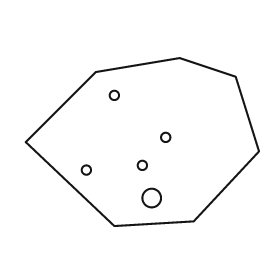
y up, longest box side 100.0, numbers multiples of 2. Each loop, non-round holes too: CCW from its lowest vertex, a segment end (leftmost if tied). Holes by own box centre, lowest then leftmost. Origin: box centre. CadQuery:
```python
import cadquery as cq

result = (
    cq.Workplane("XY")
    .moveTo(-12.0, -36.0)
    .lineTo(22.0, -34.0)
    .lineTo(50.0, -4.0)
    .lineTo(40.0, 28.0)
    .lineTo(16.0, 36.0)
    .lineTo(-20.0, 30.0)
    .lineTo(-50.0, 0.0)
    .close()
    .moveTo(4.0, -24.0)
    .circle(4.0)
    .moveTo(-24.0, -12.0)
    .circle(2.0)
    .moveTo(0.0, -10.0)
    .circle(2.0)
    .moveTo(10.0, 2.0)
    .circle(2.0)
    .moveTo(-12.0, 20.0)
    .circle(2.0)
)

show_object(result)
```